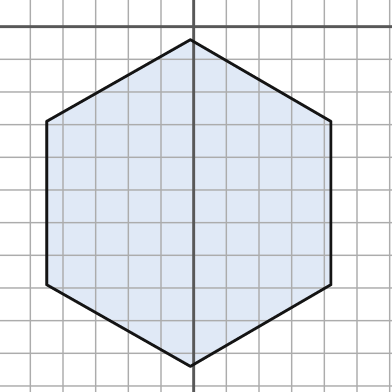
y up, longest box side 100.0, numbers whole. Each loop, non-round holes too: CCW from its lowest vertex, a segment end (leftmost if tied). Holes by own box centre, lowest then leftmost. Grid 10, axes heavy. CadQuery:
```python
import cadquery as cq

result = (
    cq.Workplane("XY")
    .moveTo(-1.0, -104.0)
    .lineTo(42.0, -79.0)
    .lineTo(42.0, -29.0)
    .lineTo(-1.0, -4.0)
    .lineTo(-45.0, -29.0)
    .lineTo(-45.0, -79.0)
    .close()
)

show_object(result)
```